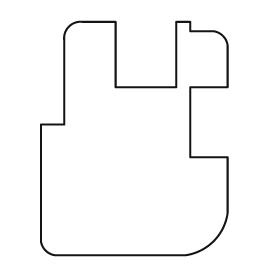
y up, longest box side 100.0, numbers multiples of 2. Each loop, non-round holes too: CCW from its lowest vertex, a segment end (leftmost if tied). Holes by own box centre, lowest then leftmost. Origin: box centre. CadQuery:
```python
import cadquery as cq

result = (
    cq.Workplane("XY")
    .moveTo(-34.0, -50.0)
    .lineTo(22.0, -50.0)
    .threePointArc((34.0, -44.0), (40.0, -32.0))
    .lineTo(40.0, -8.0)
    .lineTo(24.0, -8.0)
    .lineTo(24.0, 22.0)
    .lineTo(40.0, 22.0)
    .lineTo(40.0, 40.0)
    .threePointArc((38.0, 44.0), (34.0, 46.0))
    .lineTo(24.0, 46.0)
    .lineTo(24.0, 50.0)
    .lineTo(18.0, 50.0)
    .lineTo(18.0, 22.0)
    .lineTo(-8.0, 22.0)
    .lineTo(-8.0, 50.0)
    .lineTo(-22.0, 50.0)
    .threePointArc((-28.0, 48.0), (-30.0, 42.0))
    .lineTo(-30.0, 6.0)
    .lineTo(-40.0, 6.0)
    .lineTo(-40.0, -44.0)
    .threePointArc((-38.0, -48.0), (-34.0, -50.0))
    .close()
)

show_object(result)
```